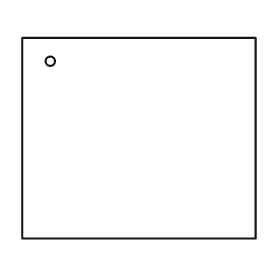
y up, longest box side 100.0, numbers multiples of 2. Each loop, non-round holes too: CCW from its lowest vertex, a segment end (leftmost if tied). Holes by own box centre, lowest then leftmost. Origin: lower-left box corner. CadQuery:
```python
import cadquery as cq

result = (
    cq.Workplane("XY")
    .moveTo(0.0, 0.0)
    .lineTo(100.0, 0.0)
    .lineTo(100.0, 86.0)
    .lineTo(0.0, 86.0)
    .close()
    .moveTo(12.0, 76.0)
    .circle(2.0)
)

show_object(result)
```